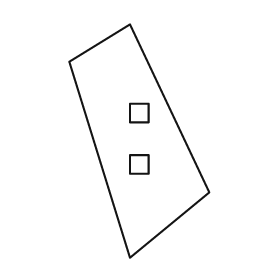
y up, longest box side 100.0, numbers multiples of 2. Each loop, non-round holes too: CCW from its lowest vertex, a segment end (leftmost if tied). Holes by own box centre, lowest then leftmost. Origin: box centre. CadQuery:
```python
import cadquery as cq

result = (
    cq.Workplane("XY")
    .moveTo(-4.0, -50.0)
    .lineTo(30.0, -22.0)
    .lineTo(-4.0, 50.0)
    .lineTo(-30.0, 34.0)
    .close()
    .moveTo(-4.0, -14.0)
    .lineTo(4.0, -14.0)
    .lineTo(4.0, -6.0)
    .lineTo(-4.0, -6.0)
    .close()
    .moveTo(-4.0, 8.0)
    .lineTo(4.0, 8.0)
    .lineTo(4.0, 16.0)
    .lineTo(-4.0, 16.0)
    .close()
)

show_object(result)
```